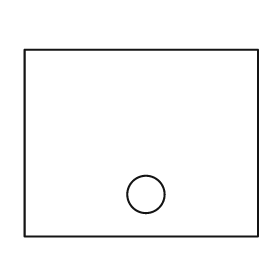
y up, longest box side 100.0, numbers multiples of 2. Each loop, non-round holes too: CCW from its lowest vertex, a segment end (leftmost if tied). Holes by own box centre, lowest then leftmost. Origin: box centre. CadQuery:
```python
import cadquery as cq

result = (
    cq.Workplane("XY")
    .moveTo(-50.0, -40.0)
    .lineTo(50.0, -40.0)
    .lineTo(50.0, 40.0)
    .lineTo(-50.0, 40.0)
    .close()
    .moveTo(2.0, -22.0)
    .circle(8.0)
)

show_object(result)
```